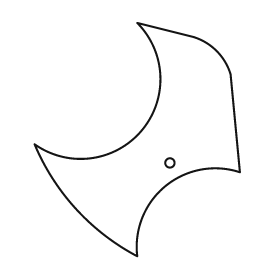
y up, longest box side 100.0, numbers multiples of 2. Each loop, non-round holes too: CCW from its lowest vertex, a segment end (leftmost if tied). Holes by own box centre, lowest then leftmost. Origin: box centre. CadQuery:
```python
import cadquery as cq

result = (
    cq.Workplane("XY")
    .moveTo(0.0, -50.0)
    .threePointArc((12.0, -20.0), (44.0, -14.0))
    .lineTo(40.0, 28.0)
    .threePointArc((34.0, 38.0), (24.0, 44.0))
    .lineTo(0.0, 50.0)
    .threePointArc((2.0, 4.0), (-44.0, -2.0))
    .threePointArc((-26.0, -30.0), (0.0, -50.0))
    .close()
    .moveTo(14.0, -10.0)
    .circle(2.0)
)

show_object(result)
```